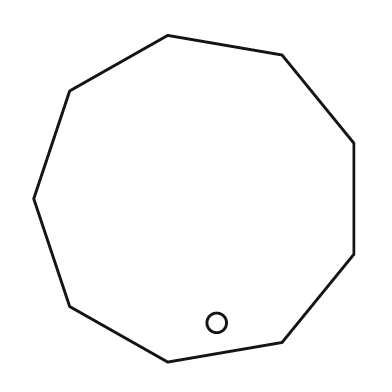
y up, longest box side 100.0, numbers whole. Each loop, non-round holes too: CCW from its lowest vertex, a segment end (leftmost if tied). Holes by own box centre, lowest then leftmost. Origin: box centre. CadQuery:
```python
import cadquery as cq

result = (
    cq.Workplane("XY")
    .moveTo(-8.0, -50.0)
    .lineTo(27.0, -44.0)
    .lineTo(49.0, -17.0)
    .lineTo(49.0, 17.0)
    .lineTo(27.0, 44.0)
    .lineTo(-8.0, 50.0)
    .lineTo(-38.0, 33.0)
    .lineTo(-49.0, 0.0)
    .lineTo(-38.0, -33.0)
    .close()
    .moveTo(7.0, -38.0)
    .circle(3.0)
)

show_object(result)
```